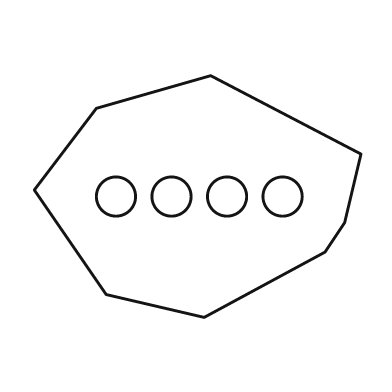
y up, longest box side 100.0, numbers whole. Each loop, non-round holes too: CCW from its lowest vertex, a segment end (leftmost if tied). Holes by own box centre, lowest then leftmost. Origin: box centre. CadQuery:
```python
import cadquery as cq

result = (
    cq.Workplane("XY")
    .moveTo(2.0, -37.0)
    .lineTo(39.0, -17.0)
    .lineTo(45.0, -8.0)
    .lineTo(50.0, 13.0)
    .lineTo(4.0, 37.0)
    .lineTo(-31.0, 27.0)
    .lineTo(-50.0, 2.0)
    .lineTo(-28.0, -30.0)
    .close()
    .moveTo(-25.0, 0.0)
    .circle(6.0)
    .moveTo(-8.0, 0.0)
    .circle(6.0)
    .moveTo(9.0, 0.0)
    .circle(6.0)
    .moveTo(26.0, 0.0)
    .circle(6.0)
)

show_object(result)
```